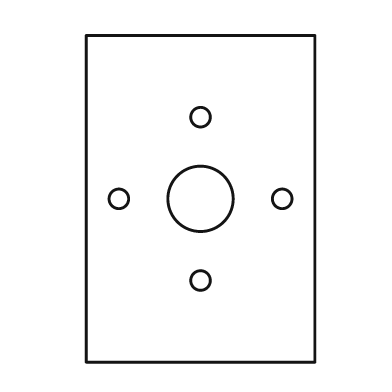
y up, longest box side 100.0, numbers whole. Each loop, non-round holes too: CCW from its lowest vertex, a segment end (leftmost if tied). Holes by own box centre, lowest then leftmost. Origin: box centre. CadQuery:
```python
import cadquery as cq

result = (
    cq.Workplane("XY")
    .moveTo(-35.0, -50.0)
    .lineTo(35.0, -50.0)
    .lineTo(35.0, 50.0)
    .lineTo(-35.0, 50.0)
    .close()
    .moveTo(0.0, -25.0)
    .circle(3.0)
    .moveTo(-25.0, 0.0)
    .circle(3.0)
    .moveTo(0.0, 0.0)
    .circle(10.0)
    .moveTo(25.0, 0.0)
    .circle(3.0)
    .moveTo(0.0, 25.0)
    .circle(3.0)
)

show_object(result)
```